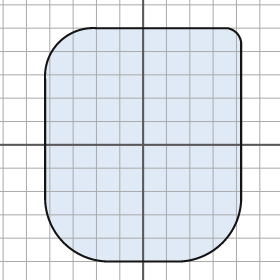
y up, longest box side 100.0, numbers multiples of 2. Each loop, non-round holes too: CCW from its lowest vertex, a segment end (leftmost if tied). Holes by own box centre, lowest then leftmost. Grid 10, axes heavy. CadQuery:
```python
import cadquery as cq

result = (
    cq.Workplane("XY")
    .moveTo(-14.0, -50.0)
    .lineTo(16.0, -50.0)
    .threePointArc((34.0, -42.0), (42.0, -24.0))
    .lineTo(42.0, 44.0)
    .threePointArc((40.0, 48.0), (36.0, 50.0))
    .lineTo(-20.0, 50.0)
    .threePointArc((-36.0, 44.0), (-42.0, 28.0))
    .lineTo(-42.0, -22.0)
    .threePointArc((-34.0, -42.0), (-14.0, -50.0))
    .close()
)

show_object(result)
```